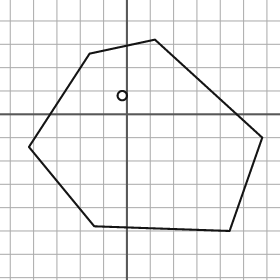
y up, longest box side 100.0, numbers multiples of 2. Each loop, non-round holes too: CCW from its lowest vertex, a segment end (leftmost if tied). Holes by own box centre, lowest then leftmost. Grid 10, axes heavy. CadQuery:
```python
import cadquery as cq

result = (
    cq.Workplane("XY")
    .moveTo(44.0, -50.0)
    .lineTo(58.0, -10.0)
    .lineTo(12.0, 32.0)
    .lineTo(-16.0, 26.0)
    .lineTo(-42.0, -14.0)
    .lineTo(-14.0, -48.0)
    .close()
    .moveTo(-2.0, 8.0)
    .circle(2.0)
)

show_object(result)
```